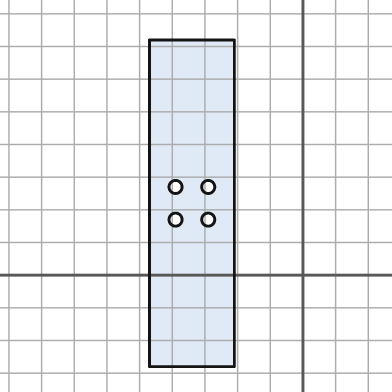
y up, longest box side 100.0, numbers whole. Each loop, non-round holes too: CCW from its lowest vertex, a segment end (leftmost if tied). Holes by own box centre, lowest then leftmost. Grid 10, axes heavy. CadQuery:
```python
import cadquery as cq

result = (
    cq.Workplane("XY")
    .moveTo(-47.0, -28.0)
    .lineTo(-21.0, -28.0)
    .lineTo(-21.0, 72.0)
    .lineTo(-47.0, 72.0)
    .close()
    .moveTo(-39.0, 17.0)
    .circle(2.0)
    .moveTo(-29.0, 17.0)
    .circle(2.0)
    .moveTo(-39.0, 27.0)
    .circle(2.0)
    .moveTo(-29.0, 27.0)
    .circle(2.0)
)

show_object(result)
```